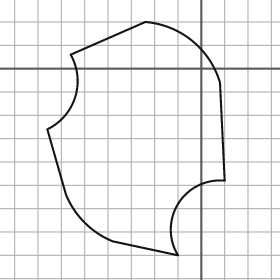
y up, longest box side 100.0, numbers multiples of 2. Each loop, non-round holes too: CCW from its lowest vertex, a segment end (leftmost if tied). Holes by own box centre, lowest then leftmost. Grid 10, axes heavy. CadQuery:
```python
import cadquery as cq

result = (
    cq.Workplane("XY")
    .moveTo(-10.0, -80.0)
    .threePointArc((-10.0, -58.0), (10.0, -48.0))
    .lineTo(8.0, -6.0)
    .threePointArc((-4.0, 12.0), (-24.0, 20.0))
    .lineTo(-56.0, 6.0)
    .threePointArc((-54.0, -12.0), (-66.0, -26.0))
    .lineTo(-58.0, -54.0)
    .threePointArc((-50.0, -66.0), (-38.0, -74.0))
    .close()
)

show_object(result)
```